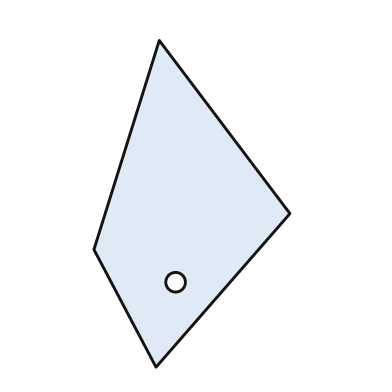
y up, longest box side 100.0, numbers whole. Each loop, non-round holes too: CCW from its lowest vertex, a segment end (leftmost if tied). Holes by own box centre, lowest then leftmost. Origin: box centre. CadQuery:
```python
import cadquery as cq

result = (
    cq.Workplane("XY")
    .moveTo(-11.0, -50.0)
    .lineTo(30.0, -3.0)
    .lineTo(-10.0, 50.0)
    .lineTo(-30.0, -14.0)
    .close()
    .moveTo(-5.0, -24.0)
    .circle(3.0)
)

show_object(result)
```